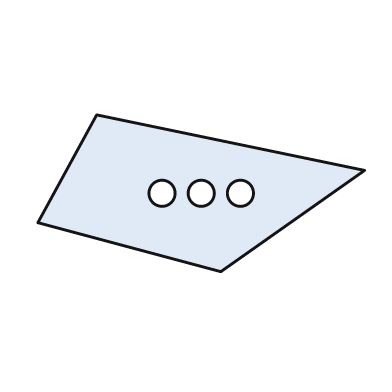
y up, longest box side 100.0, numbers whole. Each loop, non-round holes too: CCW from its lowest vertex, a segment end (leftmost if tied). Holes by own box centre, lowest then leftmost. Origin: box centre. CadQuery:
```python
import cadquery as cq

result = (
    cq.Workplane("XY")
    .moveTo(6.0, -24.0)
    .lineTo(50.0, 7.0)
    .lineTo(-32.0, 24.0)
    .lineTo(-50.0, -9.0)
    .close()
    .moveTo(-12.0, 0.0)
    .circle(4.0)
    .moveTo(0.0, 0.0)
    .circle(4.0)
    .moveTo(12.0, 0.0)
    .circle(4.0)
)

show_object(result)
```